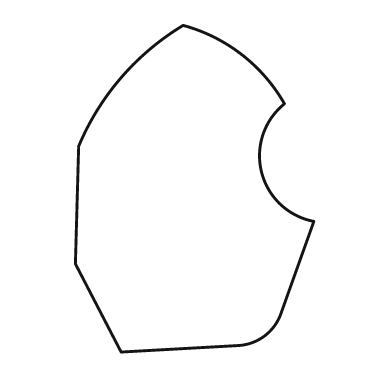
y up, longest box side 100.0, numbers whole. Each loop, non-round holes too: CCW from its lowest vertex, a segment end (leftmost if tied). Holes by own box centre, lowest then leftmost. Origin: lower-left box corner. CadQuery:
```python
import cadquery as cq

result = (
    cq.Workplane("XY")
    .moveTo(14.0, 0.0)
    .lineTo(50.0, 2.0)
    .threePointArc((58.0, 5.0), (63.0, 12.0))
    .lineTo(73.0, 40.0)
    .threePointArc((57.0, 55.0), (64.0, 76.0))
    .threePointArc((51.0, 91.0), (33.0, 100.0))
    .threePointArc((14.0, 84.0), (1.0, 63.0))
    .lineTo(0.0, 27.0)
    .close()
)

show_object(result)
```